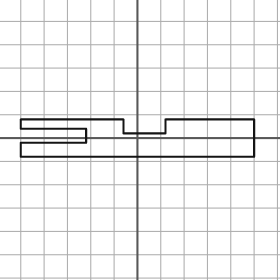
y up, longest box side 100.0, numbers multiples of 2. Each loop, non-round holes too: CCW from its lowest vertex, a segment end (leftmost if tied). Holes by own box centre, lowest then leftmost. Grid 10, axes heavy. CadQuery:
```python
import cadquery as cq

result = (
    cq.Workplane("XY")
    .moveTo(-50.0, -8.0)
    .lineTo(50.0, -8.0)
    .lineTo(50.0, 8.0)
    .lineTo(12.0, 8.0)
    .lineTo(12.0, 2.0)
    .lineTo(-6.0, 2.0)
    .lineTo(-6.0, 8.0)
    .lineTo(-50.0, 8.0)
    .lineTo(-50.0, 4.0)
    .lineTo(-22.0, 4.0)
    .lineTo(-22.0, -2.0)
    .lineTo(-50.0, -2.0)
    .close()
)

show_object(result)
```